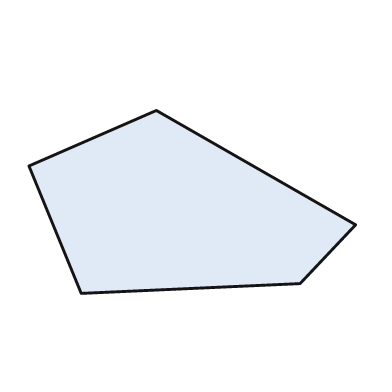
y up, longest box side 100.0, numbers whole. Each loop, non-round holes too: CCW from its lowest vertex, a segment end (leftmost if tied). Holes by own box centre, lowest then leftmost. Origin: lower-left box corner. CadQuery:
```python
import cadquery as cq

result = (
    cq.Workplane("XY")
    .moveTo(16.0, 0.0)
    .lineTo(83.0, 3.0)
    .lineTo(100.0, 21.0)
    .lineTo(39.0, 56.0)
    .lineTo(0.0, 39.0)
    .close()
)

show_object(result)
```